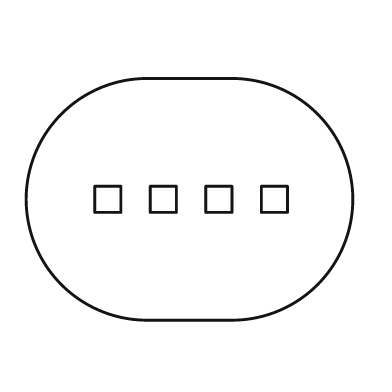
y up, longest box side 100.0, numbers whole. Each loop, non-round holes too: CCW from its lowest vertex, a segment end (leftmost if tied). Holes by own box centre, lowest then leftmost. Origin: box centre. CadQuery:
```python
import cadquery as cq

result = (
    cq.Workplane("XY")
    .moveTo(-13.0, -37.0)
    .lineTo(13.0, -37.0)
    .threePointArc((50.0, 0.0), (13.0, 37.0))
    .lineTo(-13.0, 37.0)
    .threePointArc((-50.0, 0.0), (-13.0, -37.0))
    .close()
    .moveTo(-29.0, -4.0)
    .lineTo(-21.0, -4.0)
    .lineTo(-21.0, 4.0)
    .lineTo(-29.0, 4.0)
    .close()
    .moveTo(-12.0, -4.0)
    .lineTo(-4.0, -4.0)
    .lineTo(-4.0, 4.0)
    .lineTo(-12.0, 4.0)
    .close()
    .moveTo(5.0, -4.0)
    .lineTo(13.0, -4.0)
    .lineTo(13.0, 4.0)
    .lineTo(5.0, 4.0)
    .close()
    .moveTo(22.0, -4.0)
    .lineTo(30.0, -4.0)
    .lineTo(30.0, 4.0)
    .lineTo(22.0, 4.0)
    .close()
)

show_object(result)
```